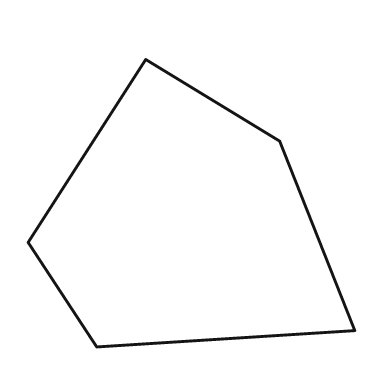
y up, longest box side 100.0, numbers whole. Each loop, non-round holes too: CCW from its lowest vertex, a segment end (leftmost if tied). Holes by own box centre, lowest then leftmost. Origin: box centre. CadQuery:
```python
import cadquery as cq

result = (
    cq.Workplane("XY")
    .moveTo(-29.0, -44.0)
    .lineTo(50.0, -39.0)
    .lineTo(27.0, 19.0)
    .lineTo(-14.0, 44.0)
    .lineTo(-50.0, -12.0)
    .close()
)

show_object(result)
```